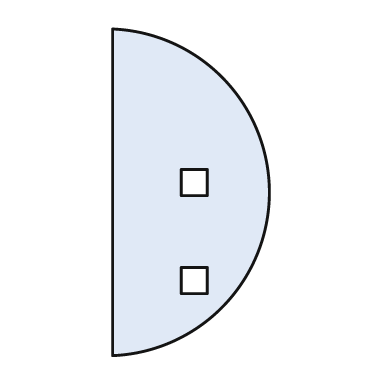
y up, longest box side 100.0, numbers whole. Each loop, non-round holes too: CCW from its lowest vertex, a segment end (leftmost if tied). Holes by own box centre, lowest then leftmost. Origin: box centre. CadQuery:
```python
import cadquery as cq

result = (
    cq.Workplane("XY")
    .moveTo(-24.0, -50.0)
    .threePointArc((24.0, 0.0), (-24.0, 50.0))
    .close()
    .moveTo(-3.0, -31.0)
    .lineTo(5.0, -31.0)
    .lineTo(5.0, -23.0)
    .lineTo(-3.0, -23.0)
    .close()
    .moveTo(-3.0, -1.0)
    .lineTo(5.0, -1.0)
    .lineTo(5.0, 7.0)
    .lineTo(-3.0, 7.0)
    .close()
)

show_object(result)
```